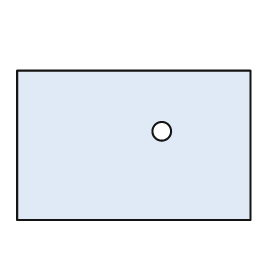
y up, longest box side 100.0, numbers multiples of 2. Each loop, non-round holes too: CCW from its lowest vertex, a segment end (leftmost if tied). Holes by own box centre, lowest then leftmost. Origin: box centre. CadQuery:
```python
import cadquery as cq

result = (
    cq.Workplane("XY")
    .moveTo(-50.0, -32.0)
    .lineTo(50.0, -32.0)
    .lineTo(50.0, 32.0)
    .lineTo(-50.0, 32.0)
    .close()
    .moveTo(12.0, 6.0)
    .circle(4.0)
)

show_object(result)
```